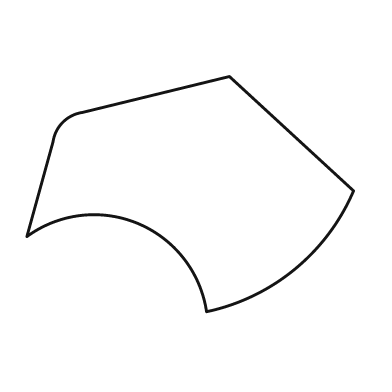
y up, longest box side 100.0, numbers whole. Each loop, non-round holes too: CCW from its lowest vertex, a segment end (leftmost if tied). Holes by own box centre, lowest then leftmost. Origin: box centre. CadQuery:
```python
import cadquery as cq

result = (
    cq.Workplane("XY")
    .moveTo(5.0, -36.0)
    .threePointArc((32.0, -23.0), (50.0, 1.0))
    .lineTo(12.0, 36.0)
    .lineTo(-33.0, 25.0)
    .threePointArc((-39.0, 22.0), (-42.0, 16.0))
    .lineTo(-50.0, -13.0)
    .threePointArc((-16.0, -9.0), (5.0, -36.0))
    .close()
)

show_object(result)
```